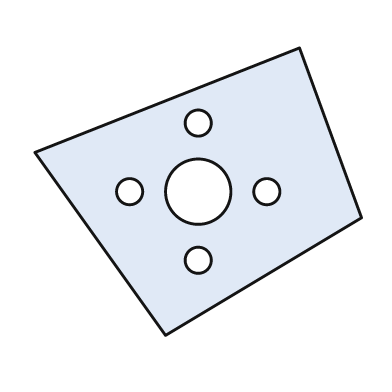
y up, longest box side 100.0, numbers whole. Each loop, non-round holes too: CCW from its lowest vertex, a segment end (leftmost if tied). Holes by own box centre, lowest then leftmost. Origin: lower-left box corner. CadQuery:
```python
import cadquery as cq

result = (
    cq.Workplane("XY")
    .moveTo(40.0, 0.0)
    .lineTo(100.0, 36.0)
    .lineTo(81.0, 88.0)
    .lineTo(0.0, 56.0)
    .close()
    .moveTo(50.0, 23.0)
    .circle(4.0)
    .moveTo(29.0, 44.0)
    .circle(4.0)
    .moveTo(50.0, 44.0)
    .circle(10.0)
    .moveTo(71.0, 44.0)
    .circle(4.0)
    .moveTo(50.0, 65.0)
    .circle(4.0)
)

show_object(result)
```